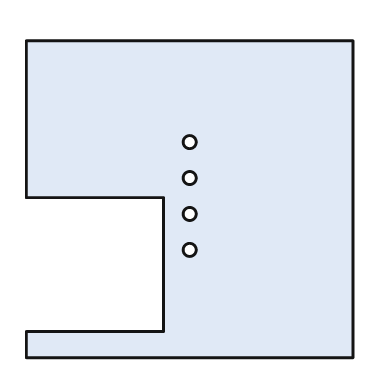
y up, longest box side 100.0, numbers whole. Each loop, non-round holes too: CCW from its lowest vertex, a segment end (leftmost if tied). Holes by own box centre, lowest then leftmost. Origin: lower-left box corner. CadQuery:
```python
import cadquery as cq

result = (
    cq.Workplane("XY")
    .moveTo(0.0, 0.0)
    .lineTo(100.0, 0.0)
    .lineTo(100.0, 97.0)
    .lineTo(0.0, 97.0)
    .lineTo(0.0, 49.0)
    .lineTo(42.0, 49.0)
    .lineTo(42.0, 8.0)
    .lineTo(0.0, 8.0)
    .close()
    .moveTo(50.0, 33.0)
    .circle(2.0)
    .moveTo(50.0, 44.0)
    .circle(2.0)
    .moveTo(50.0, 55.0)
    .circle(2.0)
    .moveTo(50.0, 66.0)
    .circle(2.0)
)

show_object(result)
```